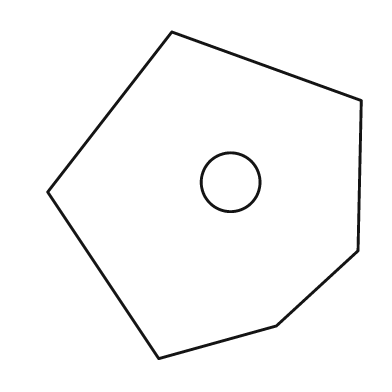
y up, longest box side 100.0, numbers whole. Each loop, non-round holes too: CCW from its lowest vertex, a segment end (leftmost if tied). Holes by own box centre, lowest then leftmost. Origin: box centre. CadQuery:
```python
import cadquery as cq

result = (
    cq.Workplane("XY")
    .moveTo(-14.0, -50.0)
    .lineTo(22.0, -40.0)
    .lineTo(47.0, -17.0)
    .lineTo(48.0, 29.0)
    .lineTo(-10.0, 50.0)
    .lineTo(-48.0, 1.0)
    .close()
    .moveTo(8.0, 4.0)
    .circle(9.0)
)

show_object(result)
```